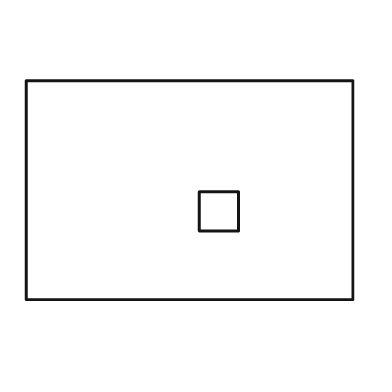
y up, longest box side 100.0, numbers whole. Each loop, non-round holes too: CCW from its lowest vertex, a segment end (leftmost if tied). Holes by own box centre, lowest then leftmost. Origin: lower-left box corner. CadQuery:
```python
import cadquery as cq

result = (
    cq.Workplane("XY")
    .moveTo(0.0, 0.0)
    .lineTo(100.0, 0.0)
    .lineTo(100.0, 67.0)
    .lineTo(0.0, 67.0)
    .close()
    .moveTo(53.0, 21.0)
    .lineTo(65.0, 21.0)
    .lineTo(65.0, 33.0)
    .lineTo(53.0, 33.0)
    .close()
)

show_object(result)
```